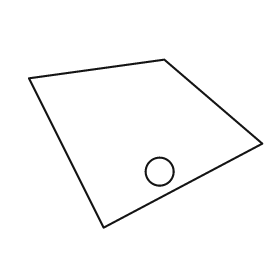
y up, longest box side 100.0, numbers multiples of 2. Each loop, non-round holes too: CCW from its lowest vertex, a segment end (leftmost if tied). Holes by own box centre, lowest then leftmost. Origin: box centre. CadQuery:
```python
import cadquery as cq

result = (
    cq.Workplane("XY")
    .moveTo(-18.0, -36.0)
    .lineTo(50.0, 0.0)
    .lineTo(8.0, 36.0)
    .lineTo(-50.0, 28.0)
    .close()
    .moveTo(6.0, -12.0)
    .circle(6.0)
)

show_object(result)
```